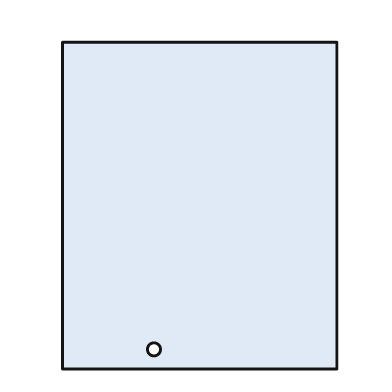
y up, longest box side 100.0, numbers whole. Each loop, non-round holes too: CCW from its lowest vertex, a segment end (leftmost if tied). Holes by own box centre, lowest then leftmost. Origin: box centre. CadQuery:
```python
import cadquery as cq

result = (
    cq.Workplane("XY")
    .moveTo(-42.0, -50.0)
    .lineTo(42.0, -50.0)
    .lineTo(42.0, 50.0)
    .lineTo(-42.0, 50.0)
    .close()
    .moveTo(-14.0, -44.0)
    .circle(2.0)
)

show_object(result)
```